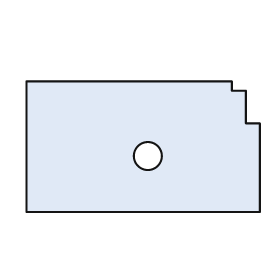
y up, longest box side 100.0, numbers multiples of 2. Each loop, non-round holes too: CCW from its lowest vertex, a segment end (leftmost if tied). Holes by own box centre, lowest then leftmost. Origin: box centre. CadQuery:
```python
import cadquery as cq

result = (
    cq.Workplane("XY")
    .moveTo(-50.0, -28.0)
    .lineTo(50.0, -28.0)
    .lineTo(50.0, 10.0)
    .lineTo(44.0, 10.0)
    .lineTo(44.0, 24.0)
    .lineTo(38.0, 24.0)
    .lineTo(38.0, 28.0)
    .lineTo(-50.0, 28.0)
    .close()
    .moveTo(2.0, -4.0)
    .circle(6.0)
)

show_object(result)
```